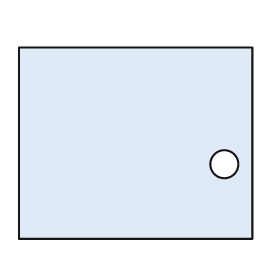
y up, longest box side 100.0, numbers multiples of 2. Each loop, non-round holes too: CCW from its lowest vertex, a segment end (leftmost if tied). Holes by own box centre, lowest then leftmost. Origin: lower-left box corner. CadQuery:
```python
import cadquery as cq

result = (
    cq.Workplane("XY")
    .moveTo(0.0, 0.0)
    .lineTo(100.0, 0.0)
    .lineTo(100.0, 82.0)
    .lineTo(0.0, 82.0)
    .close()
    .moveTo(88.0, 32.0)
    .circle(6.0)
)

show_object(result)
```